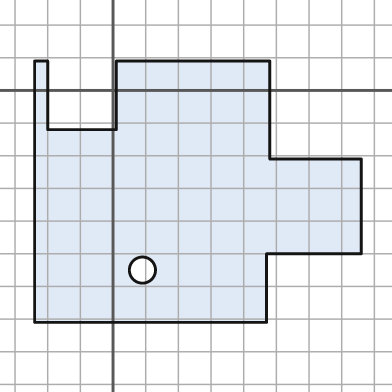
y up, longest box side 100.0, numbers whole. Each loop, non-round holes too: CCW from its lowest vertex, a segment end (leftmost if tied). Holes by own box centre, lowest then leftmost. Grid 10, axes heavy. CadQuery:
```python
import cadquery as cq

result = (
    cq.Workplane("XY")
    .moveTo(-24.0, -71.0)
    .lineTo(47.0, -71.0)
    .lineTo(47.0, -50.0)
    .lineTo(76.0, -50.0)
    .lineTo(76.0, -21.0)
    .lineTo(48.0, -21.0)
    .lineTo(48.0, 9.0)
    .lineTo(1.0, 9.0)
    .lineTo(1.0, -12.0)
    .lineTo(-20.0, -12.0)
    .lineTo(-20.0, 9.0)
    .lineTo(-24.0, 9.0)
    .close()
    .moveTo(9.0, -55.0)
    .circle(4.0)
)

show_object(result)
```